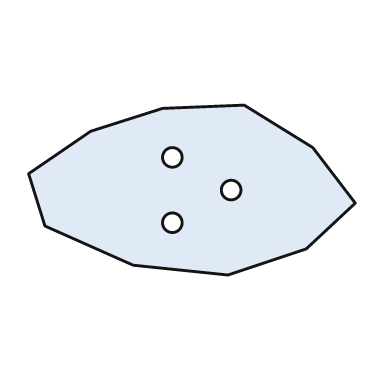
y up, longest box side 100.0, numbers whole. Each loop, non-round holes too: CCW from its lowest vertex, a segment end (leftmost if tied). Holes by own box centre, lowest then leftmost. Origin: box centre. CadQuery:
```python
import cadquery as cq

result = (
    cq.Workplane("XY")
    .moveTo(11.0, -26.0)
    .lineTo(35.0, -18.0)
    .lineTo(50.0, -4.0)
    .lineTo(37.0, 13.0)
    .lineTo(16.0, 26.0)
    .lineTo(-9.0, 25.0)
    .lineTo(-31.0, 18.0)
    .lineTo(-50.0, 5.0)
    .lineTo(-45.0, -11.0)
    .lineTo(-18.0, -23.0)
    .close()
    .moveTo(-6.0, -10.0)
    .circle(3.0)
    .moveTo(12.0, 0.0)
    .circle(3.0)
    .moveTo(-6.0, 10.0)
    .circle(3.0)
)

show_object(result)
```